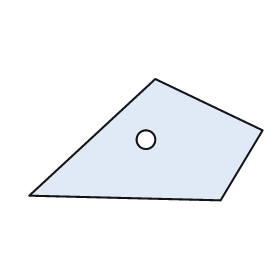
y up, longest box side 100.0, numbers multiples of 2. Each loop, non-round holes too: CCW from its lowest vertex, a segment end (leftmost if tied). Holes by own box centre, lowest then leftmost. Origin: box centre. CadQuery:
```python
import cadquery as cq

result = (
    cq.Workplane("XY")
    .moveTo(32.0, -26.0)
    .lineTo(50.0, 4.0)
    .lineTo(4.0, 26.0)
    .lineTo(-50.0, -24.0)
    .close()
    .moveTo(0.0, 0.0)
    .circle(4.0)
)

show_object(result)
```